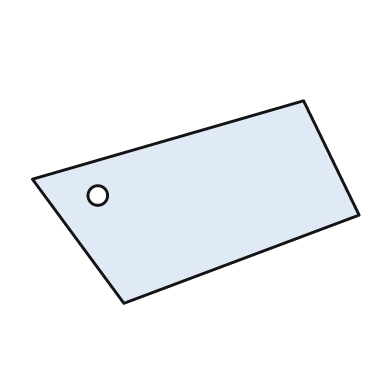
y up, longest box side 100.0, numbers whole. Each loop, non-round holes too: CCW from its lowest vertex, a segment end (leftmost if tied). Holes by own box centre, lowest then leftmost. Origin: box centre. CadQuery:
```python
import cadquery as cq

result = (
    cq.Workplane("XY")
    .moveTo(-22.0, -31.0)
    .lineTo(50.0, -4.0)
    .lineTo(33.0, 31.0)
    .lineTo(-50.0, 7.0)
    .close()
    .moveTo(-30.0, 2.0)
    .circle(3.0)
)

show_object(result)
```